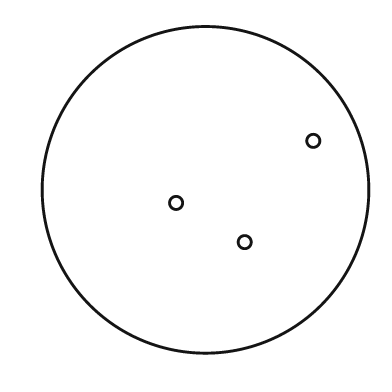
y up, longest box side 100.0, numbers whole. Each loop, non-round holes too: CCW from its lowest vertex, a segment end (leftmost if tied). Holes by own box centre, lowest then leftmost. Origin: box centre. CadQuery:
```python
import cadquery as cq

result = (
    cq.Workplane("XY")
    .moveTo(0.0, 0.0)
    .circle(50.0)
    .moveTo(12.0, -16.0)
    .circle(2.0)
    .moveTo(-9.0, -4.0)
    .circle(2.0)
    .moveTo(33.0, 15.0)
    .circle(2.0)
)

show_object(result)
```